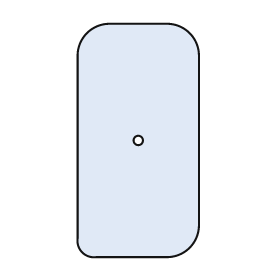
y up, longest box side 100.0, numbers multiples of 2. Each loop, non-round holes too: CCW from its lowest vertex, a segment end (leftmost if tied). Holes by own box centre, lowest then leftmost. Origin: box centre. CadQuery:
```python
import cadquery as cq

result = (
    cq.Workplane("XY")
    .moveTo(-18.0, -50.0)
    .lineTo(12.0, -50.0)
    .threePointArc((22.0, -46.0), (26.0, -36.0))
    .lineTo(26.0, 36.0)
    .threePointArc((22.0, 46.0), (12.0, 50.0))
    .lineTo(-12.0, 50.0)
    .threePointArc((-22.0, 46.0), (-26.0, 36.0))
    .lineTo(-26.0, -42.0)
    .threePointArc((-24.0, -48.0), (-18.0, -50.0))
    .close()
    .moveTo(0.0, 0.0)
    .circle(2.0)
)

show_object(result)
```